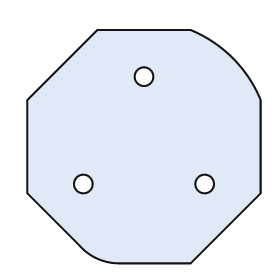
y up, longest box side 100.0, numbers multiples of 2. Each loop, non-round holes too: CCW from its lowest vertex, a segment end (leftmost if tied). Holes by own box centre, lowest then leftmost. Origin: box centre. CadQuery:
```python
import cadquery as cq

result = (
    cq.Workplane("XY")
    .moveTo(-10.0, -50.0)
    .lineTo(20.0, -50.0)
    .lineTo(50.0, -20.0)
    .lineTo(50.0, 20.0)
    .threePointArc((38.0, 38.0), (20.0, 50.0))
    .lineTo(-20.0, 50.0)
    .lineTo(-50.0, 20.0)
    .lineTo(-50.0, -20.0)
    .lineTo(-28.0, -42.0)
    .threePointArc((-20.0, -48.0), (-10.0, -50.0))
    .close()
    .moveTo(-26.0, -16.0)
    .circle(4.0)
    .moveTo(26.0, -16.0)
    .circle(4.0)
    .moveTo(0.0, 30.0)
    .circle(4.0)
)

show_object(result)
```